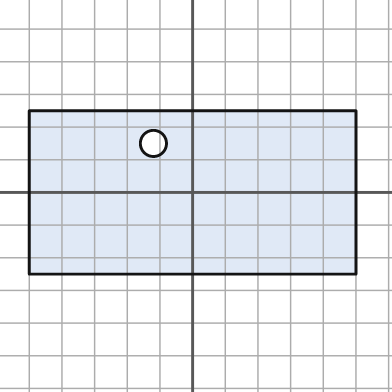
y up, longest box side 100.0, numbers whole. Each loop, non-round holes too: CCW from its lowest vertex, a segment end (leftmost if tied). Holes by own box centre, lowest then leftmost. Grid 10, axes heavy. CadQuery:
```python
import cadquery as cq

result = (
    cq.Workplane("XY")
    .moveTo(-50.0, -25.0)
    .lineTo(50.0, -25.0)
    .lineTo(50.0, 25.0)
    .lineTo(-50.0, 25.0)
    .close()
    .moveTo(-12.0, 15.0)
    .circle(4.0)
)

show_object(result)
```